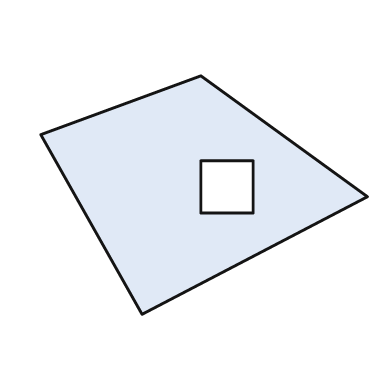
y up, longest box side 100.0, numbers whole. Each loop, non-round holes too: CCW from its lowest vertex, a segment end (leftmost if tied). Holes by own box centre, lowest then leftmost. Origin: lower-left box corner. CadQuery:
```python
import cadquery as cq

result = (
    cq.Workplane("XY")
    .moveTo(31.0, 0.0)
    .lineTo(100.0, 36.0)
    .lineTo(49.0, 73.0)
    .lineTo(0.0, 55.0)
    .close()
    .moveTo(49.0, 31.0)
    .lineTo(65.0, 31.0)
    .lineTo(65.0, 47.0)
    .lineTo(49.0, 47.0)
    .close()
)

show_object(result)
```